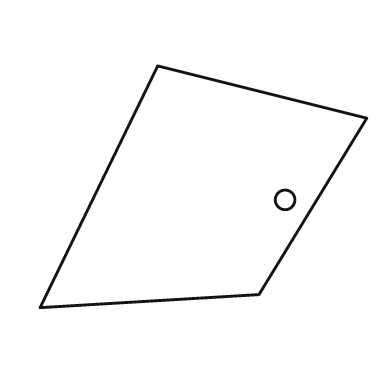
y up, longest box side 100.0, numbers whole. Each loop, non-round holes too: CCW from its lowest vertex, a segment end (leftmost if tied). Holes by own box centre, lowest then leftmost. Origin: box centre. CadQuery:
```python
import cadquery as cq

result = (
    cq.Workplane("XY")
    .moveTo(-50.0, -37.0)
    .lineTo(17.0, -33.0)
    .lineTo(50.0, 21.0)
    .lineTo(-14.0, 37.0)
    .close()
    .moveTo(25.0, -4.0)
    .circle(3.0)
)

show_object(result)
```